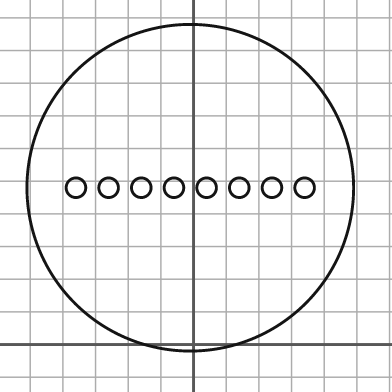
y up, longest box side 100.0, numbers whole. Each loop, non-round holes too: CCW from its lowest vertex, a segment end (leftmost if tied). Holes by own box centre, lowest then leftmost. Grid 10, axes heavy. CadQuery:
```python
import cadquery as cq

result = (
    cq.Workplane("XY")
    .moveTo(-1.0, 48.0)
    .circle(50.0)
    .moveTo(-36.0, 48.0)
    .circle(3.0)
    .moveTo(-26.0, 48.0)
    .circle(3.0)
    .moveTo(-16.0, 48.0)
    .circle(3.0)
    .moveTo(-6.0, 48.0)
    .circle(3.0)
    .moveTo(4.0, 48.0)
    .circle(3.0)
    .moveTo(14.0, 48.0)
    .circle(3.0)
    .moveTo(24.0, 48.0)
    .circle(3.0)
    .moveTo(34.0, 48.0)
    .circle(3.0)
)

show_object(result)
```